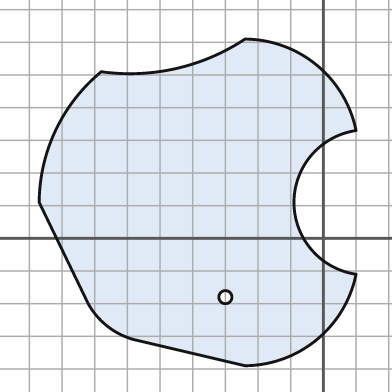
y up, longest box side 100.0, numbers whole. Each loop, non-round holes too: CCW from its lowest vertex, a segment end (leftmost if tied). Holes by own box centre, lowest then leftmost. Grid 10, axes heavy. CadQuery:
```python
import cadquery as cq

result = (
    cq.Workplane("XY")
    .moveTo(-24.0, -39.0)
    .threePointArc((-2.0, -31.0), (10.0, -11.0))
    .threePointArc((-9.0, 11.0), (10.0, 33.0))
    .threePointArc((-2.0, 53.0), (-24.0, 61.0))
    .threePointArc((-45.0, 52.0), (-68.0, 51.0))
    .threePointArc((-82.0, 33.0), (-87.0, 11.0))
    .lineTo(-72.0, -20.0)
    .threePointArc((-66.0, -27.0), (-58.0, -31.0))
    .close()
    .moveTo(-30.0, -18.0)
    .circle(2.0)
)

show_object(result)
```